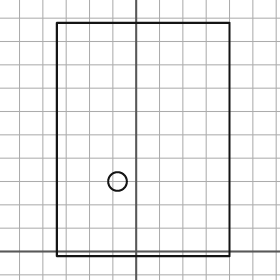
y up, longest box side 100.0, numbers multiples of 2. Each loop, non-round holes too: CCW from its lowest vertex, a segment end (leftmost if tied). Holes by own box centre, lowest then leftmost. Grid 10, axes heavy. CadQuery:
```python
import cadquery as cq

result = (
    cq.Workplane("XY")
    .moveTo(-34.0, -2.0)
    .lineTo(40.0, -2.0)
    .lineTo(40.0, 98.0)
    .lineTo(-34.0, 98.0)
    .close()
    .moveTo(-8.0, 30.0)
    .circle(4.0)
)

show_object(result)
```